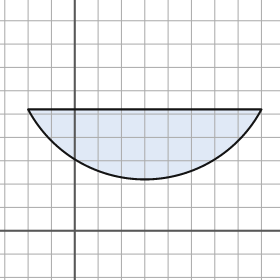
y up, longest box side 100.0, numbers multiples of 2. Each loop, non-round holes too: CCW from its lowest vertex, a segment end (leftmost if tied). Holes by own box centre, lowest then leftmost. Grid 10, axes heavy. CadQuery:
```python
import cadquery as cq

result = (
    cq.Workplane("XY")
    .moveTo(-20.0, 52.0)
    .threePointArc((30.0, 22.0), (80.0, 52.0))
    .close()
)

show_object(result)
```